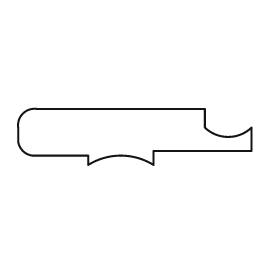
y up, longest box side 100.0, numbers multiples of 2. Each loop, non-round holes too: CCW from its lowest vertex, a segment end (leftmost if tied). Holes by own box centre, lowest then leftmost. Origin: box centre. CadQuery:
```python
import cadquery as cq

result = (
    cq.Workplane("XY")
    .moveTo(-20.0, -12.0)
    .threePointArc((-6.0, -8.0), (8.0, -12.0))
    .lineTo(8.0, -6.0)
    .lineTo(50.0, -6.0)
    .lineTo(50.0, 4.0)
    .threePointArc((40.0, 0.0), (30.0, 4.0))
    .lineTo(30.0, 12.0)
    .lineTo(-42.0, 12.0)
    .threePointArc((-48.0, 10.0), (-50.0, 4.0))
    .lineTo(-50.0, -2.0)
    .threePointArc((-48.0, -6.0), (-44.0, -8.0))
    .lineTo(-20.0, -8.0)
    .close()
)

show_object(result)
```